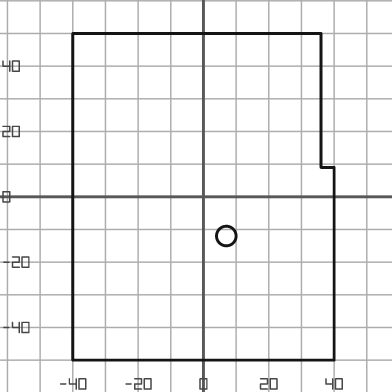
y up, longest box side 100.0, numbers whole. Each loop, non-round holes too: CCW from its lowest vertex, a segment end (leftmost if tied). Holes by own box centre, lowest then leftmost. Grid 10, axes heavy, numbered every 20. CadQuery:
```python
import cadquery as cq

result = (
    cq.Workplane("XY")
    .moveTo(-40.0, -50.0)
    .lineTo(40.0, -50.0)
    .lineTo(40.0, 9.0)
    .lineTo(36.0, 9.0)
    .lineTo(36.0, 50.0)
    .lineTo(-40.0, 50.0)
    .close()
    .moveTo(7.0, -12.0)
    .circle(3.0)
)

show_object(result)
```